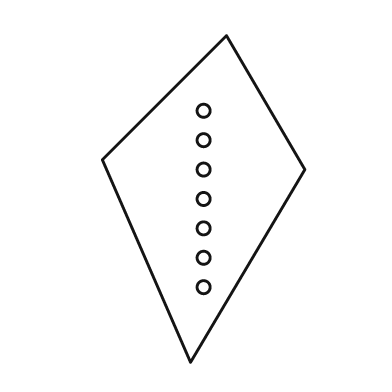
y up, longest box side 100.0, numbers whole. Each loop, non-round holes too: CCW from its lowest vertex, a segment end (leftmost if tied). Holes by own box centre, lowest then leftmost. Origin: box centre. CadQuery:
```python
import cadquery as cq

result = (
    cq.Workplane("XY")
    .moveTo(-4.0, -50.0)
    .lineTo(31.0, 9.0)
    .lineTo(7.0, 50.0)
    .lineTo(-31.0, 12.0)
    .close()
    .moveTo(0.0, -27.0)
    .circle(2.0)
    .moveTo(0.0, -18.0)
    .circle(2.0)
    .moveTo(0.0, -9.0)
    .circle(2.0)
    .moveTo(0.0, 0.0)
    .circle(2.0)
    .moveTo(0.0, 9.0)
    .circle(2.0)
    .moveTo(0.0, 18.0)
    .circle(2.0)
    .moveTo(0.0, 27.0)
    .circle(2.0)
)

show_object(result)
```